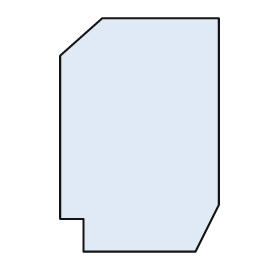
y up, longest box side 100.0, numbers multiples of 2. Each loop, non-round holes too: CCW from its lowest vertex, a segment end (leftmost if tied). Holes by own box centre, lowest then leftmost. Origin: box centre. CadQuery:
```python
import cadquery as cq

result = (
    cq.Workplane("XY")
    .moveTo(-24.0, -50.0)
    .lineTo(24.0, -50.0)
    .lineTo(34.0, -30.0)
    .lineTo(34.0, 50.0)
    .lineTo(-16.0, 50.0)
    .lineTo(-34.0, 34.0)
    .lineTo(-34.0, -36.0)
    .lineTo(-24.0, -36.0)
    .close()
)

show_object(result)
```